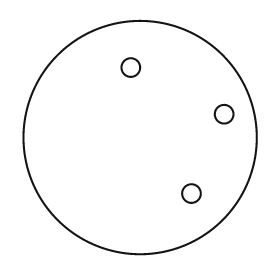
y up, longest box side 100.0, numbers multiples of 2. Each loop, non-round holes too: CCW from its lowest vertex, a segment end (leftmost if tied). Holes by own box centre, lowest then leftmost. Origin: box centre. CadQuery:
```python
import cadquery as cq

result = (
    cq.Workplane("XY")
    .moveTo(0.0, 0.0)
    .circle(50.0)
    .moveTo(22.0, -24.0)
    .circle(4.0)
    .moveTo(36.0, 10.0)
    .circle(4.0)
    .moveTo(-4.0, 30.0)
    .circle(4.0)
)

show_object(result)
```